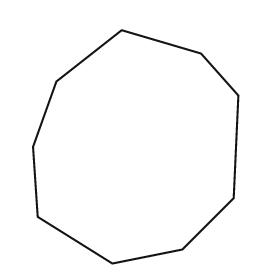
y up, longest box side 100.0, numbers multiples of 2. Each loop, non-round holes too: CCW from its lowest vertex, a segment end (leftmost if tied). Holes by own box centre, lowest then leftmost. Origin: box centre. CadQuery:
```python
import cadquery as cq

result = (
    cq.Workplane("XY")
    .moveTo(-10.0, -50.0)
    .lineTo(20.0, -44.0)
    .lineTo(42.0, -22.0)
    .lineTo(44.0, 22.0)
    .lineTo(28.0, 40.0)
    .lineTo(-6.0, 50.0)
    .lineTo(-34.0, 28.0)
    .lineTo(-44.0, 0.0)
    .lineTo(-42.0, -30.0)
    .close()
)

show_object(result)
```